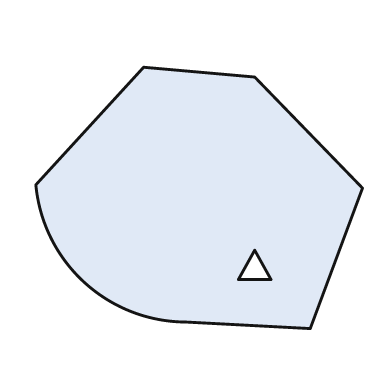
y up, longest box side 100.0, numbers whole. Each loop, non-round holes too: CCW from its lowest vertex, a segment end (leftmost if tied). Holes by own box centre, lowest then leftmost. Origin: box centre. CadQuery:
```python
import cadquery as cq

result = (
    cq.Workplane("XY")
    .moveTo(34.0, -40.0)
    .lineTo(50.0, 3.0)
    .lineTo(17.0, 37.0)
    .lineTo(-17.0, 40.0)
    .lineTo(-50.0, 4.0)
    .threePointArc((-35.0, -26.0), (-4.0, -38.0))
    .close()
    .moveTo(12.0, -25.0)
    .lineTo(22.0, -25.0)
    .lineTo(17.0, -16.0)
    .close()
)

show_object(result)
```